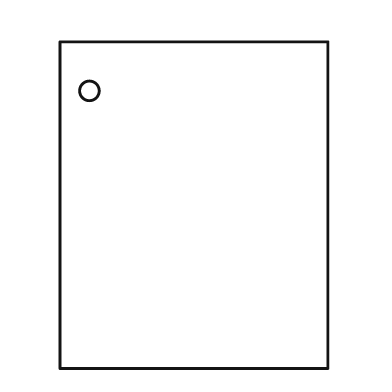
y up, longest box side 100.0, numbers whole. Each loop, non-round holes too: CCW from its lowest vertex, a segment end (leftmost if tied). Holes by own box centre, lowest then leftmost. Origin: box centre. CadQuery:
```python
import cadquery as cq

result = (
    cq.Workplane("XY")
    .moveTo(-41.0, -50.0)
    .lineTo(41.0, -50.0)
    .lineTo(41.0, 50.0)
    .lineTo(-41.0, 50.0)
    .close()
    .moveTo(-32.0, 35.0)
    .circle(3.0)
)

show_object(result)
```